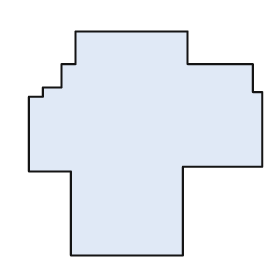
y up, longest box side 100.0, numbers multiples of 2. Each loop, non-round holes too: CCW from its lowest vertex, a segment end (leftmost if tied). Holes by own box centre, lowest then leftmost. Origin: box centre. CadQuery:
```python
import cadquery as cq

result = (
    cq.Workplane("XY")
    .moveTo(-32.0, -48.0)
    .lineTo(16.0, -48.0)
    .lineTo(16.0, -10.0)
    .lineTo(50.0, -10.0)
    .lineTo(50.0, 22.0)
    .lineTo(46.0, 22.0)
    .lineTo(46.0, 34.0)
    .lineTo(18.0, 34.0)
    .lineTo(18.0, 48.0)
    .lineTo(-30.0, 48.0)
    .lineTo(-30.0, 34.0)
    .lineTo(-36.0, 34.0)
    .lineTo(-36.0, 24.0)
    .lineTo(-44.0, 24.0)
    .lineTo(-44.0, 20.0)
    .lineTo(-50.0, 20.0)
    .lineTo(-50.0, -12.0)
    .lineTo(-32.0, -12.0)
    .close()
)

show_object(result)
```